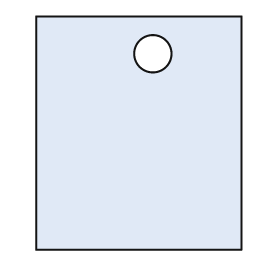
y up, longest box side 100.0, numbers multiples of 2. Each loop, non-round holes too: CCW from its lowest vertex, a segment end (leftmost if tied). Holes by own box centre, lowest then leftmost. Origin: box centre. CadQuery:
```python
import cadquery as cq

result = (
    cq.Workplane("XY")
    .moveTo(-44.0, -50.0)
    .lineTo(44.0, -50.0)
    .lineTo(44.0, 50.0)
    .lineTo(-44.0, 50.0)
    .close()
    .moveTo(6.0, 34.0)
    .circle(8.0)
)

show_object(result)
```